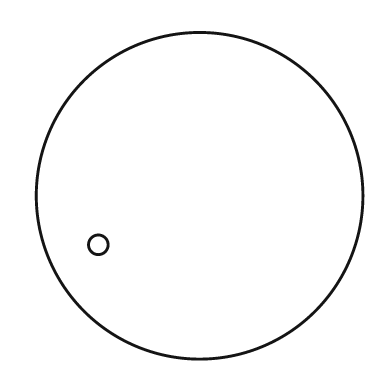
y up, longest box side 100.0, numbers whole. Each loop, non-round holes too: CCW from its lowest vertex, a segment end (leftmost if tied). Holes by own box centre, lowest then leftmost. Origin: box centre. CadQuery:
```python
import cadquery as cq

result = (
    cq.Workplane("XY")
    .moveTo(0.0, 0.0)
    .circle(50.0)
    .moveTo(-31.0, -15.0)
    .circle(3.0)
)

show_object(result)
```